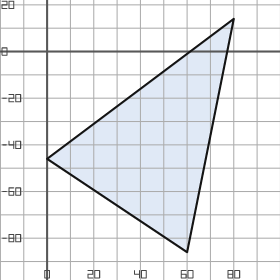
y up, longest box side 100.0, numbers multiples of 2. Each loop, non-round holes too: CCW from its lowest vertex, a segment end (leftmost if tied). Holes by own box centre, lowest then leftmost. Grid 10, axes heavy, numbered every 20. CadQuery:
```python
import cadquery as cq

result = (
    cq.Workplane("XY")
    .moveTo(60.0, -86.0)
    .lineTo(80.0, 14.0)
    .lineTo(0.0, -46.0)
    .close()
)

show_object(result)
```